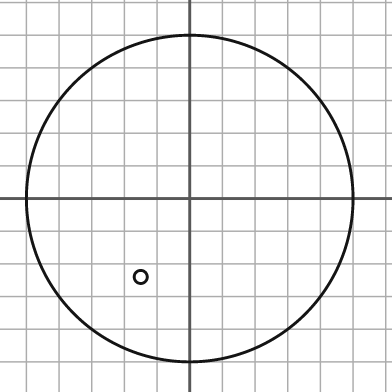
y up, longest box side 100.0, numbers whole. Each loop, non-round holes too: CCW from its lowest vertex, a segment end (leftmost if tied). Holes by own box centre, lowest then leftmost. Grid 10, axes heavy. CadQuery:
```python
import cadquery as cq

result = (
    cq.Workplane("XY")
    .moveTo(0.0, 0.0)
    .circle(50.0)
    .moveTo(-15.0, -24.0)
    .circle(2.0)
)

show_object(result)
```